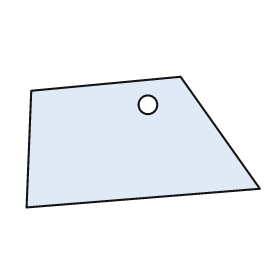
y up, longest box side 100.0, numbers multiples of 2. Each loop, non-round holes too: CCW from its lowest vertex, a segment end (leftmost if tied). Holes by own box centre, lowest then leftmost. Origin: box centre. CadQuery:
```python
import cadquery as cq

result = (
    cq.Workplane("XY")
    .moveTo(-50.0, -28.0)
    .lineTo(50.0, -20.0)
    .lineTo(16.0, 28.0)
    .lineTo(-48.0, 22.0)
    .close()
    .moveTo(2.0, 16.0)
    .circle(4.0)
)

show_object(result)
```